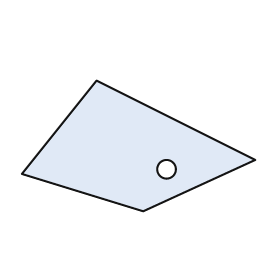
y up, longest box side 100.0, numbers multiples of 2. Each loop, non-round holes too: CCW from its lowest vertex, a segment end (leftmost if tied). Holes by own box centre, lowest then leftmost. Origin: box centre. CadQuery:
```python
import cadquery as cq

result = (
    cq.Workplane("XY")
    .moveTo(2.0, -28.0)
    .lineTo(50.0, -6.0)
    .lineTo(-18.0, 28.0)
    .lineTo(-50.0, -12.0)
    .close()
    .moveTo(12.0, -10.0)
    .circle(4.0)
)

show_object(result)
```